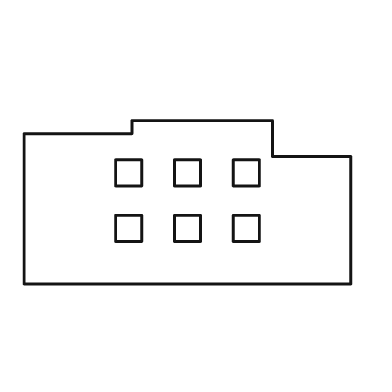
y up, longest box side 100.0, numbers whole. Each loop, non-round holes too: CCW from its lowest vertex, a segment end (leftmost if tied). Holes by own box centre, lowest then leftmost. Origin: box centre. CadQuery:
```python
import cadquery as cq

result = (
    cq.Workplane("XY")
    .moveTo(-50.0, -25.0)
    .lineTo(50.0, -25.0)
    .lineTo(50.0, 14.0)
    .lineTo(26.0, 14.0)
    .lineTo(26.0, 25.0)
    .lineTo(-17.0, 25.0)
    .lineTo(-17.0, 21.0)
    .lineTo(-50.0, 21.0)
    .close()
    .moveTo(-22.0, -12.0)
    .lineTo(-14.0, -12.0)
    .lineTo(-14.0, -4.0)
    .lineTo(-22.0, -4.0)
    .close()
    .moveTo(-4.0, -12.0)
    .lineTo(4.0, -12.0)
    .lineTo(4.0, -4.0)
    .lineTo(-4.0, -4.0)
    .close()
    .moveTo(14.0, -12.0)
    .lineTo(22.0, -12.0)
    .lineTo(22.0, -4.0)
    .lineTo(14.0, -4.0)
    .close()
    .moveTo(-22.0, 5.0)
    .lineTo(-14.0, 5.0)
    .lineTo(-14.0, 13.0)
    .lineTo(-22.0, 13.0)
    .close()
    .moveTo(-4.0, 5.0)
    .lineTo(4.0, 5.0)
    .lineTo(4.0, 13.0)
    .lineTo(-4.0, 13.0)
    .close()
    .moveTo(14.0, 5.0)
    .lineTo(22.0, 5.0)
    .lineTo(22.0, 13.0)
    .lineTo(14.0, 13.0)
    .close()
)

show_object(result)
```